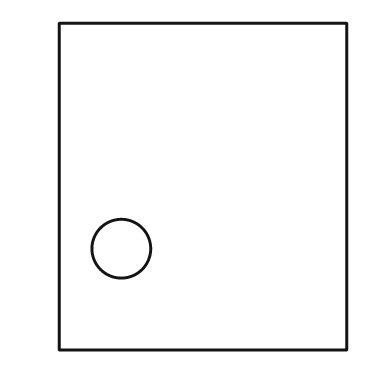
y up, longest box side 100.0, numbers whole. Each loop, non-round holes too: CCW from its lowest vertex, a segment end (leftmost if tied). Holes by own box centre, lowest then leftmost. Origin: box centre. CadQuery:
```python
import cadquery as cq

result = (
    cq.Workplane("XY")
    .moveTo(-44.0, -50.0)
    .lineTo(44.0, -50.0)
    .lineTo(44.0, 50.0)
    .lineTo(-44.0, 50.0)
    .close()
    .moveTo(-25.0, -19.0)
    .circle(9.0)
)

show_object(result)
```